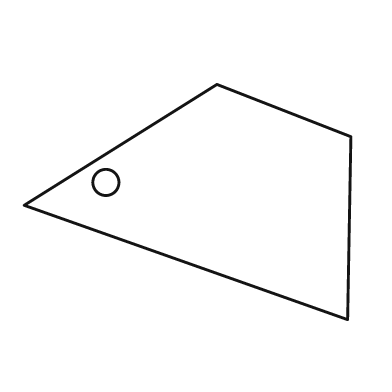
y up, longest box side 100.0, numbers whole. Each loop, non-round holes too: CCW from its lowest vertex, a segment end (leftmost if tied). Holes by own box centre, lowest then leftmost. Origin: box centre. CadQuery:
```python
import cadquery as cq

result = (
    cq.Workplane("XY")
    .moveTo(49.0, -36.0)
    .lineTo(50.0, 20.0)
    .lineTo(9.0, 36.0)
    .lineTo(-50.0, -1.0)
    .close()
    .moveTo(-25.0, 6.0)
    .circle(4.0)
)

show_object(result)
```